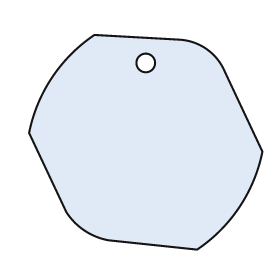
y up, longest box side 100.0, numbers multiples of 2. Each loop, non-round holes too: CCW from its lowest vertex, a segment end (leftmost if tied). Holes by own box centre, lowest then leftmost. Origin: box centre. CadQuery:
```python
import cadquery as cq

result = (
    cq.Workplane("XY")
    .moveTo(22.0, -46.0)
    .threePointArc((40.0, -28.0), (50.0, -4.0))
    .lineTo(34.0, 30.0)
    .threePointArc((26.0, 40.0), (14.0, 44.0))
    .lineTo(-22.0, 46.0)
    .threePointArc((-40.0, 28.0), (-50.0, 4.0))
    .lineTo(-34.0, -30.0)
    .threePointArc((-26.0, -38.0), (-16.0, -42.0))
    .close()
    .moveTo(0.0, 34.0)
    .circle(4.0)
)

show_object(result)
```